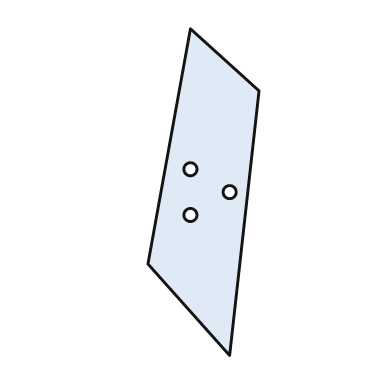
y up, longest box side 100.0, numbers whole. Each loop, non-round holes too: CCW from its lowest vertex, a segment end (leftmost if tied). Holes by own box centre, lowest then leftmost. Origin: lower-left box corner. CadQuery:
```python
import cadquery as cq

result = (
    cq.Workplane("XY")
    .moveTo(25.0, 0.0)
    .lineTo(34.0, 81.0)
    .lineTo(13.0, 100.0)
    .lineTo(0.0, 28.0)
    .close()
    .moveTo(13.0, 43.0)
    .circle(2.0)
    .moveTo(25.0, 50.0)
    .circle(2.0)
    .moveTo(13.0, 57.0)
    .circle(2.0)
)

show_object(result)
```